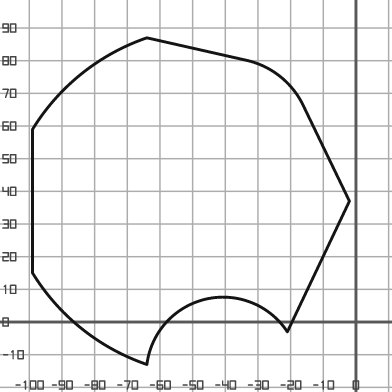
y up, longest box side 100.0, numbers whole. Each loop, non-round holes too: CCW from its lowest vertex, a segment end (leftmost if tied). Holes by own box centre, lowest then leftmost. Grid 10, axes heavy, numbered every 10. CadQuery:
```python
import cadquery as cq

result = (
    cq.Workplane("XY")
    .moveTo(-64.0, -13.0)
    .threePointArc((-46.0, 7.0), (-21.0, -3.0))
    .lineTo(-2.0, 37.0)
    .lineTo(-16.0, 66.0)
    .threePointArc((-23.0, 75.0), (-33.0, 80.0))
    .lineTo(-64.0, 87.0)
    .threePointArc((-84.0, 76.0), (-99.0, 59.0))
    .lineTo(-99.0, 15.0)
    .threePointArc((-84.0, -2.0), (-64.0, -13.0))
    .close()
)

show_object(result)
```